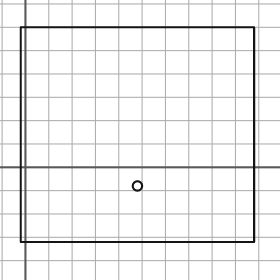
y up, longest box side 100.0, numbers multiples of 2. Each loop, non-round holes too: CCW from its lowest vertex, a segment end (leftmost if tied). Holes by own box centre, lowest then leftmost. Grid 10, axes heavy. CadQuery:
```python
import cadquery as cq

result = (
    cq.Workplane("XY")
    .moveTo(-2.0, -32.0)
    .lineTo(98.0, -32.0)
    .lineTo(98.0, 60.0)
    .lineTo(-2.0, 60.0)
    .close()
    .moveTo(48.0, -8.0)
    .circle(2.0)
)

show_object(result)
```